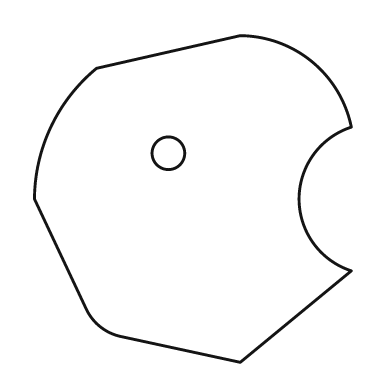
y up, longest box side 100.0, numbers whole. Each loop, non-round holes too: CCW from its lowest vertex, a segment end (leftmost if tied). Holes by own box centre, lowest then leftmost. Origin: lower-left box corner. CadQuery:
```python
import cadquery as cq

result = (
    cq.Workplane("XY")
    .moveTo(63.0, 0.0)
    .lineTo(97.0, 28.0)
    .threePointArc((81.0, 50.0), (97.0, 72.0))
    .threePointArc((85.0, 92.0), (63.0, 100.0))
    .lineTo(19.0, 90.0)
    .threePointArc((5.0, 72.0), (0.0, 50.0))
    .lineTo(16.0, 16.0)
    .threePointArc((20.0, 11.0), (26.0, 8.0))
    .close()
    .moveTo(41.0, 64.0)
    .circle(5.0)
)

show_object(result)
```